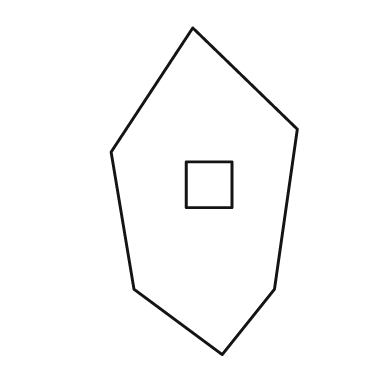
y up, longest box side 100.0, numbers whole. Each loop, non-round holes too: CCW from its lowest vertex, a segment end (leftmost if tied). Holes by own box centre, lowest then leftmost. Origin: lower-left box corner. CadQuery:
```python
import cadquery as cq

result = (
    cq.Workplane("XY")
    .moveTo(34.0, 0.0)
    .lineTo(50.0, 20.0)
    .lineTo(57.0, 69.0)
    .lineTo(25.0, 100.0)
    .lineTo(0.0, 62.0)
    .lineTo(7.0, 20.0)
    .close()
    .moveTo(23.0, 45.0)
    .lineTo(37.0, 45.0)
    .lineTo(37.0, 59.0)
    .lineTo(23.0, 59.0)
    .close()
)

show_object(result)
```